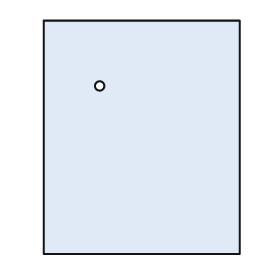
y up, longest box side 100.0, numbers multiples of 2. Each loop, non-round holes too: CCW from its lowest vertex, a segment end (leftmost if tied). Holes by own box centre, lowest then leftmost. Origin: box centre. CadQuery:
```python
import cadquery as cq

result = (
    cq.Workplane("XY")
    .moveTo(-42.0, -50.0)
    .lineTo(42.0, -50.0)
    .lineTo(42.0, 50.0)
    .lineTo(-42.0, 50.0)
    .close()
    .moveTo(-18.0, 22.0)
    .circle(2.0)
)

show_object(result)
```